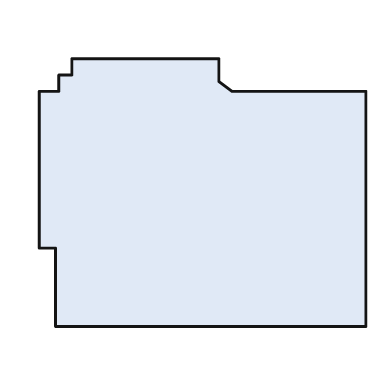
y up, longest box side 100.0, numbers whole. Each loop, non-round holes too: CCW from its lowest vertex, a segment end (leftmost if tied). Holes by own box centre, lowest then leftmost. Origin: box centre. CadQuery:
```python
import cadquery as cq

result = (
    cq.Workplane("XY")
    .moveTo(-45.0, -41.0)
    .lineTo(50.0, -41.0)
    .lineTo(50.0, 31.0)
    .lineTo(9.0, 31.0)
    .lineTo(5.0, 34.0)
    .lineTo(5.0, 41.0)
    .lineTo(-40.0, 41.0)
    .lineTo(-40.0, 36.0)
    .lineTo(-44.0, 36.0)
    .lineTo(-44.0, 31.0)
    .lineTo(-50.0, 31.0)
    .lineTo(-50.0, -17.0)
    .lineTo(-45.0, -17.0)
    .close()
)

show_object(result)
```